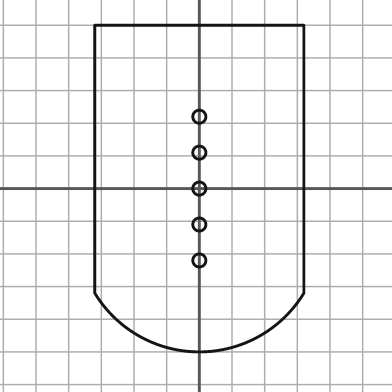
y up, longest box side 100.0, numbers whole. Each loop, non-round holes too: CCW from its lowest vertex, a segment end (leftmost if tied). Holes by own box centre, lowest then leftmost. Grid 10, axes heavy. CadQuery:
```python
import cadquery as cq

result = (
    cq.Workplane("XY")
    .moveTo(-32.0, -32.0)
    .threePointArc((0.0, -50.0), (32.0, -32.0))
    .lineTo(32.0, 50.0)
    .lineTo(-32.0, 50.0)
    .close()
    .moveTo(0.0, -22.0)
    .circle(2.0)
    .moveTo(0.0, -11.0)
    .circle(2.0)
    .moveTo(0.0, 0.0)
    .circle(2.0)
    .moveTo(0.0, 11.0)
    .circle(2.0)
    .moveTo(0.0, 22.0)
    .circle(2.0)
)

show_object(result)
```